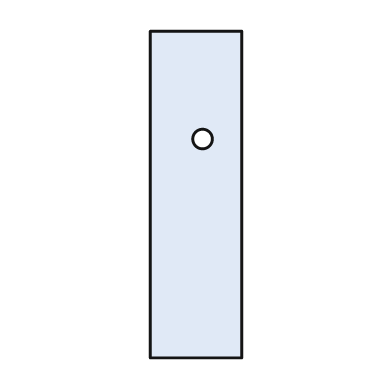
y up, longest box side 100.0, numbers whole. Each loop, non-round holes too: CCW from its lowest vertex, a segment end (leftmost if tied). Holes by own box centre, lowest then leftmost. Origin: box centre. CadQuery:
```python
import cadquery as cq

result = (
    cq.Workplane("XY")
    .moveTo(-14.0, -50.0)
    .lineTo(14.0, -50.0)
    .lineTo(14.0, 50.0)
    .lineTo(-14.0, 50.0)
    .close()
    .moveTo(2.0, 17.0)
    .circle(3.0)
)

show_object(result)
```